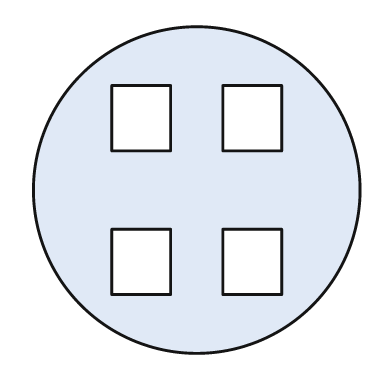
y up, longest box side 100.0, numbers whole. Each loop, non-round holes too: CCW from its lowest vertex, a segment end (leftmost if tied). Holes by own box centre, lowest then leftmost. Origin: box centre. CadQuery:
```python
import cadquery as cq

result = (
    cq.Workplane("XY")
    .moveTo(0.0, 0.0)
    .circle(50.0)
    .moveTo(-26.0, -32.0)
    .lineTo(-8.0, -32.0)
    .lineTo(-8.0, -12.0)
    .lineTo(-26.0, -12.0)
    .close()
    .moveTo(8.0, -32.0)
    .lineTo(26.0, -32.0)
    .lineTo(26.0, -12.0)
    .lineTo(8.0, -12.0)
    .close()
    .moveTo(-26.0, 12.0)
    .lineTo(-8.0, 12.0)
    .lineTo(-8.0, 32.0)
    .lineTo(-26.0, 32.0)
    .close()
    .moveTo(8.0, 12.0)
    .lineTo(26.0, 12.0)
    .lineTo(26.0, 32.0)
    .lineTo(8.0, 32.0)
    .close()
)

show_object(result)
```